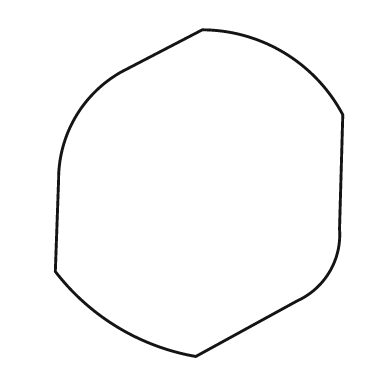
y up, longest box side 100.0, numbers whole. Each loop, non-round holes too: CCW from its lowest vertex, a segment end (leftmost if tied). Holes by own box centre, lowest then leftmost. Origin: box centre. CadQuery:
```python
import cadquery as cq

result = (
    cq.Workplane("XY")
    .moveTo(-1.0, -50.0)
    .lineTo(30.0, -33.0)
    .threePointArc((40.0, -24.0), (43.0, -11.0))
    .lineTo(44.0, 24.0)
    .threePointArc((26.0, 43.0), (1.0, 50.0))
    .lineTo(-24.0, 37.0)
    .threePointArc((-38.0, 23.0), (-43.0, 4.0))
    .lineTo(-44.0, -24.0)
    .threePointArc((-25.0, -41.0), (-1.0, -50.0))
    .close()
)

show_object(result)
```